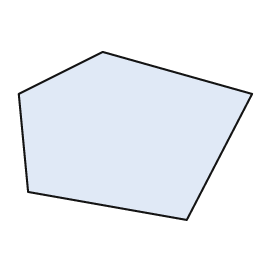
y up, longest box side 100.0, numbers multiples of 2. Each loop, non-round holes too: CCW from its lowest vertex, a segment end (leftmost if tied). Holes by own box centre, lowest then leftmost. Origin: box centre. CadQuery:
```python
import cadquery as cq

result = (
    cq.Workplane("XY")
    .moveTo(22.0, -36.0)
    .lineTo(50.0, 18.0)
    .lineTo(-14.0, 36.0)
    .lineTo(-50.0, 18.0)
    .lineTo(-46.0, -24.0)
    .close()
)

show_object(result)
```